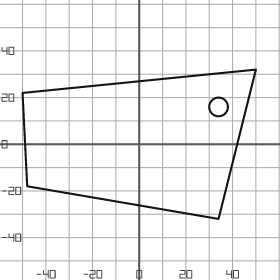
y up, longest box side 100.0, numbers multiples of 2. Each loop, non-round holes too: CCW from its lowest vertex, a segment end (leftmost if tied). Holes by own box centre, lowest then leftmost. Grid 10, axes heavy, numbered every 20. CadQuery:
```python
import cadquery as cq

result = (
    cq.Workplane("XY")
    .moveTo(34.0, -32.0)
    .lineTo(50.0, 32.0)
    .lineTo(-50.0, 22.0)
    .lineTo(-48.0, -18.0)
    .close()
    .moveTo(34.0, 16.0)
    .circle(4.0)
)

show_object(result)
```